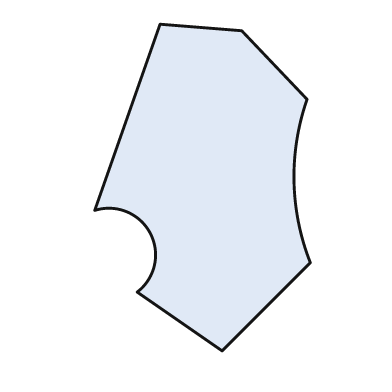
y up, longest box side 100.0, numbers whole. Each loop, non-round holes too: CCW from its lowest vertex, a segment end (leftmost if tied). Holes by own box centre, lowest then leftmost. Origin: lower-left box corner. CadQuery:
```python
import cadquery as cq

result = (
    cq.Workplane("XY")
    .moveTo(39.0, 0.0)
    .lineTo(66.0, 27.0)
    .threePointArc((61.0, 52.0), (65.0, 77.0))
    .lineTo(45.0, 98.0)
    .lineTo(20.0, 100.0)
    .lineTo(0.0, 43.0)
    .threePointArc((17.0, 36.0), (13.0, 18.0))
    .close()
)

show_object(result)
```